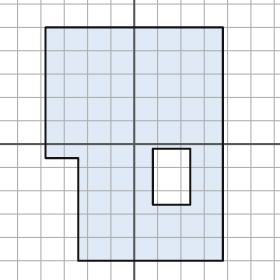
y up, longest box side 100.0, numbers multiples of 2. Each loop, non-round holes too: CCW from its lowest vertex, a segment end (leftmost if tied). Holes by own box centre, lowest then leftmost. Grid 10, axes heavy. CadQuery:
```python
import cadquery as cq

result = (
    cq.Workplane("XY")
    .moveTo(-24.0, -50.0)
    .lineTo(38.0, -50.0)
    .lineTo(38.0, 50.0)
    .lineTo(-38.0, 50.0)
    .lineTo(-38.0, -6.0)
    .lineTo(-24.0, -6.0)
    .close()
    .moveTo(8.0, -26.0)
    .lineTo(24.0, -26.0)
    .lineTo(24.0, -2.0)
    .lineTo(8.0, -2.0)
    .close()
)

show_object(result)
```